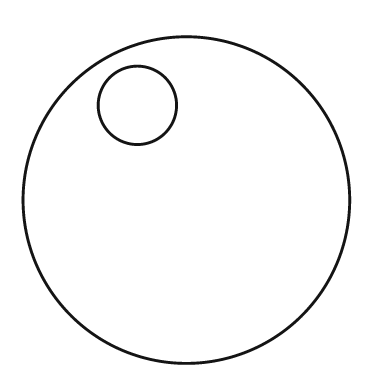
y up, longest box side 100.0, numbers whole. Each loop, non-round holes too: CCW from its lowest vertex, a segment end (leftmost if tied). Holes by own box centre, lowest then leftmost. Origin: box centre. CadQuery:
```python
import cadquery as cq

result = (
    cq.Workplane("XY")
    .moveTo(0.0, 0.0)
    .circle(50.0)
    .moveTo(-15.0, 29.0)
    .circle(12.0)
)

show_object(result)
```